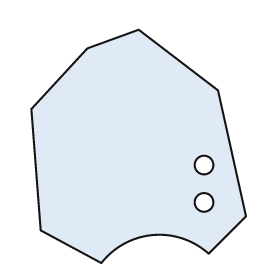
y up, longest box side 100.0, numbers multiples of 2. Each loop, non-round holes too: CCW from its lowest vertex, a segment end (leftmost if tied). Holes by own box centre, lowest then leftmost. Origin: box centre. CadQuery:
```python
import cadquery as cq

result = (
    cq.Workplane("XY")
    .moveTo(-16.0, -50.0)
    .threePointArc((6.0, -38.0), (30.0, -46.0))
    .lineTo(46.0, -30.0)
    .lineTo(34.0, 24.0)
    .lineTo(0.0, 50.0)
    .lineTo(-22.0, 42.0)
    .lineTo(-46.0, 16.0)
    .lineTo(-42.0, -36.0)
    .close()
    .moveTo(28.0, -24.0)
    .circle(4.0)
    .moveTo(28.0, -8.0)
    .circle(4.0)
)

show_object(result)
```